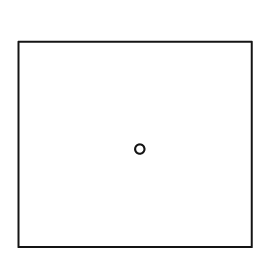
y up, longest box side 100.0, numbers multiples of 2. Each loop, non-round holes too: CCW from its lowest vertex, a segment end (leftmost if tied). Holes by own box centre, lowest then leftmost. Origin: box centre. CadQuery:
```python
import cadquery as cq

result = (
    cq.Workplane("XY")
    .moveTo(-50.0, -44.0)
    .lineTo(50.0, -44.0)
    .lineTo(50.0, 44.0)
    .lineTo(-50.0, 44.0)
    .close()
    .moveTo(2.0, -2.0)
    .circle(2.0)
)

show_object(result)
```